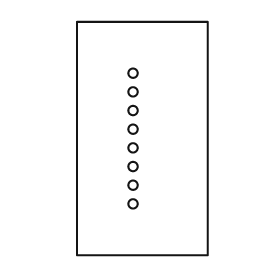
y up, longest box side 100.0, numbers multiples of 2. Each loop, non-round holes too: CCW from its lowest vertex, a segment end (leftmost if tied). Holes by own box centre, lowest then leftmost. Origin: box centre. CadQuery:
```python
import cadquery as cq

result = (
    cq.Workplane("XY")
    .moveTo(-28.0, -50.0)
    .lineTo(28.0, -50.0)
    .lineTo(28.0, 50.0)
    .lineTo(-28.0, 50.0)
    .close()
    .moveTo(-4.0, -28.0)
    .circle(2.0)
    .moveTo(-4.0, -20.0)
    .circle(2.0)
    .moveTo(-4.0, -12.0)
    .circle(2.0)
    .moveTo(-4.0, -4.0)
    .circle(2.0)
    .moveTo(-4.0, 4.0)
    .circle(2.0)
    .moveTo(-4.0, 12.0)
    .circle(2.0)
    .moveTo(-4.0, 20.0)
    .circle(2.0)
    .moveTo(-4.0, 28.0)
    .circle(2.0)
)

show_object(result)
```